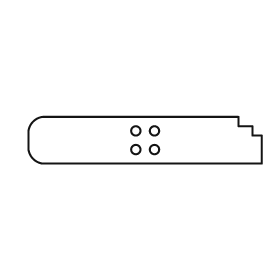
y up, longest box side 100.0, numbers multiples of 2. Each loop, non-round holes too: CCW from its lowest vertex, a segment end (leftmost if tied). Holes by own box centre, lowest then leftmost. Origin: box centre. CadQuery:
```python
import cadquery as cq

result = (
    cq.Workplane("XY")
    .moveTo(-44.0, -10.0)
    .lineTo(50.0, -10.0)
    .lineTo(50.0, 2.0)
    .lineTo(46.0, 2.0)
    .lineTo(46.0, 6.0)
    .lineTo(40.0, 6.0)
    .lineTo(40.0, 10.0)
    .lineTo(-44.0, 10.0)
    .threePointArc((-48.0, 8.0), (-50.0, 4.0))
    .lineTo(-50.0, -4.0)
    .threePointArc((-48.0, -8.0), (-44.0, -10.0))
    .close()
    .moveTo(-4.0, -4.0)
    .circle(2.0)
    .moveTo(4.0, -4.0)
    .circle(2.0)
    .moveTo(-4.0, 4.0)
    .circle(2.0)
    .moveTo(4.0, 4.0)
    .circle(2.0)
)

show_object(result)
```